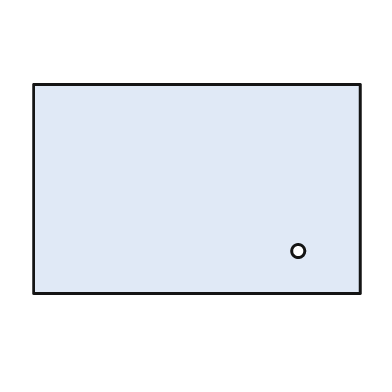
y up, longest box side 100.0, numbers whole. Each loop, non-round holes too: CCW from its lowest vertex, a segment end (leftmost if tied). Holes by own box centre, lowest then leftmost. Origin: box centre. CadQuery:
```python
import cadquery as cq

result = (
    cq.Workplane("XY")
    .moveTo(-50.0, -32.0)
    .lineTo(50.0, -32.0)
    .lineTo(50.0, 32.0)
    .lineTo(-50.0, 32.0)
    .close()
    .moveTo(31.0, -19.0)
    .circle(2.0)
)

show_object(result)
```